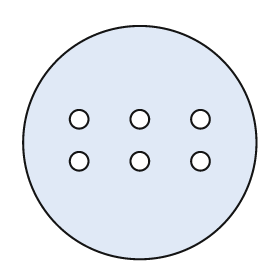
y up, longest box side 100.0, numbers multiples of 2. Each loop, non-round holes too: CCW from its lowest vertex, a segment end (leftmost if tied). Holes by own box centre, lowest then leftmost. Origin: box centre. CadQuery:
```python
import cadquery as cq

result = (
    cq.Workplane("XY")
    .moveTo(0.0, 0.0)
    .circle(50.0)
    .moveTo(-26.0, -8.0)
    .circle(4.0)
    .moveTo(0.0, -8.0)
    .circle(4.0)
    .moveTo(26.0, -8.0)
    .circle(4.0)
    .moveTo(-26.0, 10.0)
    .circle(4.0)
    .moveTo(0.0, 10.0)
    .circle(4.0)
    .moveTo(26.0, 10.0)
    .circle(4.0)
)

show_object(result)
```